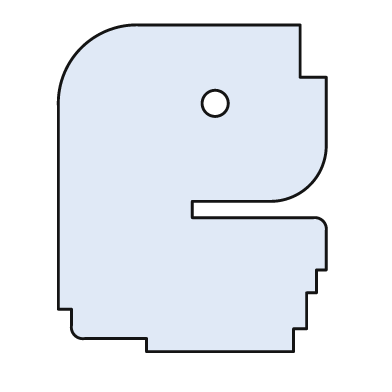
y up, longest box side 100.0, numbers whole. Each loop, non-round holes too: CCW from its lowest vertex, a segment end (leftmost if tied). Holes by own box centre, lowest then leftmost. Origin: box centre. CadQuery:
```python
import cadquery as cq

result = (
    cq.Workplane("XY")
    .moveTo(-14.0, -50.0)
    .lineTo(31.0, -50.0)
    .lineTo(31.0, -43.0)
    .lineTo(35.0, -43.0)
    .lineTo(35.0, -32.0)
    .lineTo(38.0, -32.0)
    .lineTo(38.0, -25.0)
    .lineTo(41.0, -25.0)
    .lineTo(41.0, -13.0)
    .threePointArc((40.0, -10.0), (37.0, -9.0))
    .lineTo(0.0, -9.0)
    .lineTo(0.0, -4.0)
    .lineTo(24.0, -4.0)
    .threePointArc((36.0, 1.0), (41.0, 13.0))
    .lineTo(41.0, 34.0)
    .lineTo(33.0, 34.0)
    .lineTo(33.0, 50.0)
    .lineTo(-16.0, 50.0)
    .threePointArc((-34.0, 43.0), (-41.0, 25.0))
    .lineTo(-41.0, -37.0)
    .lineTo(-37.0, -37.0)
    .lineTo(-37.0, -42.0)
    .threePointArc((-36.0, -45.0), (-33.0, -46.0))
    .lineTo(-14.0, -46.0)
    .close()
    .moveTo(7.0, 26.0)
    .circle(4.0)
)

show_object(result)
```